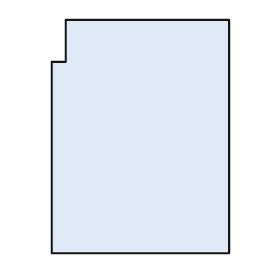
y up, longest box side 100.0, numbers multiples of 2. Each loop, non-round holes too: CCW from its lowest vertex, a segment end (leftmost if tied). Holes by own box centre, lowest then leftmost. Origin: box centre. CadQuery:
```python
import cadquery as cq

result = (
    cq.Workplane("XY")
    .moveTo(-38.0, -50.0)
    .lineTo(38.0, -50.0)
    .lineTo(38.0, 50.0)
    .lineTo(-32.0, 50.0)
    .lineTo(-32.0, 32.0)
    .lineTo(-38.0, 32.0)
    .close()
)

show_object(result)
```